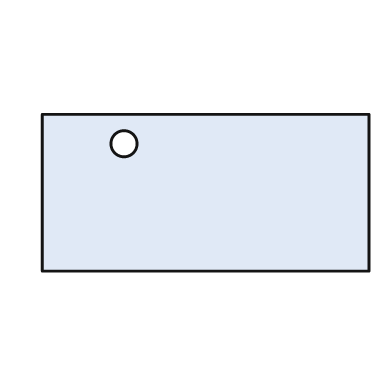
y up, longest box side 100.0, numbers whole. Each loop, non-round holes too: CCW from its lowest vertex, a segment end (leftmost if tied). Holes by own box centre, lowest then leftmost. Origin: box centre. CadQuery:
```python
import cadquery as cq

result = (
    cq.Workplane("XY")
    .moveTo(-50.0, -24.0)
    .lineTo(50.0, -24.0)
    .lineTo(50.0, 24.0)
    .lineTo(-50.0, 24.0)
    .close()
    .moveTo(-25.0, 15.0)
    .circle(4.0)
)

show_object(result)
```